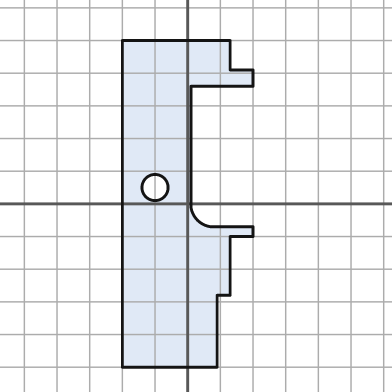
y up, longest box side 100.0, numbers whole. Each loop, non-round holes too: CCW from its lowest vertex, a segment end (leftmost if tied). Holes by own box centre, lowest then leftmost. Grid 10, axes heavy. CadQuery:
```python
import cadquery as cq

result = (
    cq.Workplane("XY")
    .moveTo(-20.0, -50.0)
    .lineTo(9.0, -50.0)
    .lineTo(9.0, -28.0)
    .lineTo(13.0, -28.0)
    .lineTo(13.0, -10.0)
    .lineTo(20.0, -10.0)
    .lineTo(20.0, -7.0)
    .lineTo(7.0, -7.0)
    .threePointArc((3.0, -5.0), (1.0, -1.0))
    .lineTo(1.0, 36.0)
    .lineTo(20.0, 36.0)
    .lineTo(20.0, 41.0)
    .lineTo(13.0, 41.0)
    .lineTo(13.0, 50.0)
    .lineTo(-20.0, 50.0)
    .close()
    .moveTo(-10.0, 5.0)
    .circle(4.0)
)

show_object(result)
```